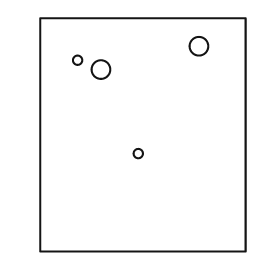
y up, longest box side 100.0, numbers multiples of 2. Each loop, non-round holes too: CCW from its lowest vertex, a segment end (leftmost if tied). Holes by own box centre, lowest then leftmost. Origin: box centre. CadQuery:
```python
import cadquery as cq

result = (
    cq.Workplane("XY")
    .moveTo(-44.0, -50.0)
    .lineTo(44.0, -50.0)
    .lineTo(44.0, 50.0)
    .lineTo(-44.0, 50.0)
    .close()
    .moveTo(-2.0, -8.0)
    .circle(2.0)
    .moveTo(-18.0, 28.0)
    .circle(4.0)
    .moveTo(-28.0, 32.0)
    .circle(2.0)
    .moveTo(24.0, 38.0)
    .circle(4.0)
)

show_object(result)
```